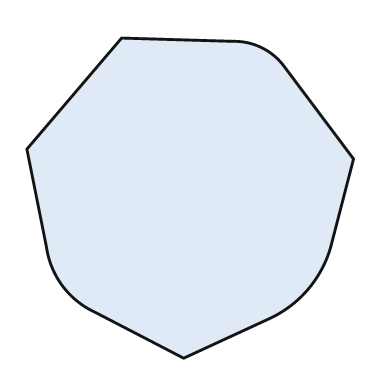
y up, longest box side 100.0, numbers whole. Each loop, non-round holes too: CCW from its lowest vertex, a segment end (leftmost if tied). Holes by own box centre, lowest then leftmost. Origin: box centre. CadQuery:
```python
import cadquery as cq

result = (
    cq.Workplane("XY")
    .moveTo(-2.0, -49.0)
    .lineTo(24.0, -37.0)
    .threePointArc((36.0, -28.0), (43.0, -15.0))
    .lineTo(50.0, 12.0)
    .lineTo(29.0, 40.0)
    .threePointArc((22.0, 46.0), (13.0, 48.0))
    .lineTo(-21.0, 49.0)
    .lineTo(-50.0, 15.0)
    .lineTo(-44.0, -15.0)
    .threePointArc((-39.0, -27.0), (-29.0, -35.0))
    .close()
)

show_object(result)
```